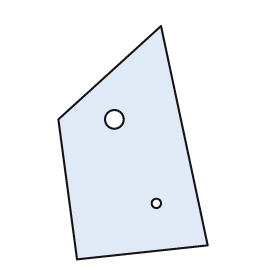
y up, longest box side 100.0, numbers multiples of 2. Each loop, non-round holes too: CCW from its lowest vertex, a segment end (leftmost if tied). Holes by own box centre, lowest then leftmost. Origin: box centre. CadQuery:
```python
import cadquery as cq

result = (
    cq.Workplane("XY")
    .moveTo(-24.0, -50.0)
    .lineTo(32.0, -44.0)
    .lineTo(12.0, 50.0)
    .lineTo(-32.0, 10.0)
    .close()
    .moveTo(10.0, -26.0)
    .circle(2.0)
    .moveTo(-8.0, 10.0)
    .circle(4.0)
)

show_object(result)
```